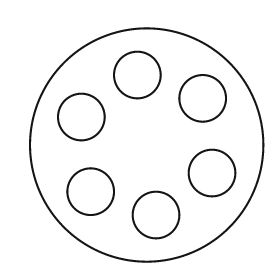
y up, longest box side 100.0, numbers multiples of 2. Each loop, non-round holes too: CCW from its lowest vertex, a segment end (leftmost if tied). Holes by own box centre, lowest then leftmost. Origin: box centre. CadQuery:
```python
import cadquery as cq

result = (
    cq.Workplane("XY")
    .moveTo(0.0, 0.0)
    .circle(50.0)
    .moveTo(4.0, -30.0)
    .circle(10.0)
    .moveTo(-24.0, -20.0)
    .circle(10.0)
    .moveTo(28.0, -12.0)
    .circle(10.0)
    .moveTo(-28.0, 12.0)
    .circle(10.0)
    .moveTo(24.0, 20.0)
    .circle(10.0)
    .moveTo(-4.0, 30.0)
    .circle(10.0)
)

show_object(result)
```